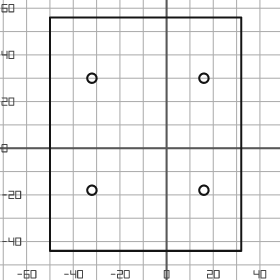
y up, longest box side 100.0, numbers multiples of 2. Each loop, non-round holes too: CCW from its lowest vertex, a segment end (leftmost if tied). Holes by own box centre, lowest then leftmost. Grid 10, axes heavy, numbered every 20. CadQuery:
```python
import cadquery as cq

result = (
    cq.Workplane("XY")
    .moveTo(-50.0, -44.0)
    .lineTo(32.0, -44.0)
    .lineTo(32.0, 56.0)
    .lineTo(-50.0, 56.0)
    .close()
    .moveTo(-32.0, -18.0)
    .circle(2.0)
    .moveTo(16.0, -18.0)
    .circle(2.0)
    .moveTo(-32.0, 30.0)
    .circle(2.0)
    .moveTo(16.0, 30.0)
    .circle(2.0)
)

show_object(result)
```